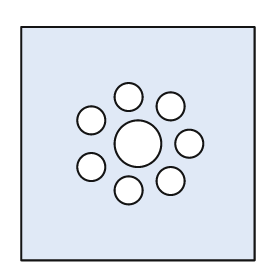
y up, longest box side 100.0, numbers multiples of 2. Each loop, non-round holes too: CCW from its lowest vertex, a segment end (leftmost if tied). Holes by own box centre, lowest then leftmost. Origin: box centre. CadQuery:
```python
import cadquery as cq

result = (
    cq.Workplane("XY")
    .moveTo(-50.0, -50.0)
    .lineTo(50.0, -50.0)
    .lineTo(50.0, 50.0)
    .lineTo(-50.0, 50.0)
    .close()
    .moveTo(-4.0, -20.0)
    .circle(6.0)
    .moveTo(14.0, -16.0)
    .circle(6.0)
    .moveTo(-20.0, -10.0)
    .circle(6.0)
    .moveTo(0.0, 0.0)
    .circle(10.0)
    .moveTo(22.0, 0.0)
    .circle(6.0)
    .moveTo(-20.0, 10.0)
    .circle(6.0)
    .moveTo(14.0, 16.0)
    .circle(6.0)
    .moveTo(-4.0, 20.0)
    .circle(6.0)
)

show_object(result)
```